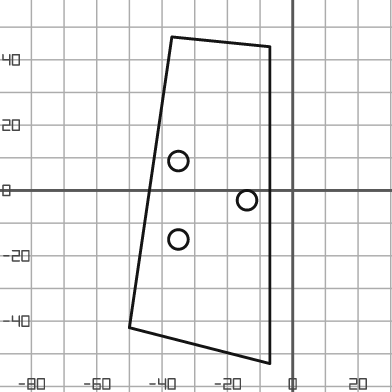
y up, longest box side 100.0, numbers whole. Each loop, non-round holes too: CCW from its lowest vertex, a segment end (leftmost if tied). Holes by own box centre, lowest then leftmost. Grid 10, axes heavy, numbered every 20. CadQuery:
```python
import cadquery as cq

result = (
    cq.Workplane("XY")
    .moveTo(-7.0, -53.0)
    .lineTo(-7.0, 44.0)
    .lineTo(-37.0, 47.0)
    .lineTo(-50.0, -42.0)
    .close()
    .moveTo(-35.0, -15.0)
    .circle(3.0)
    .moveTo(-14.0, -3.0)
    .circle(3.0)
    .moveTo(-35.0, 9.0)
    .circle(3.0)
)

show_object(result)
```